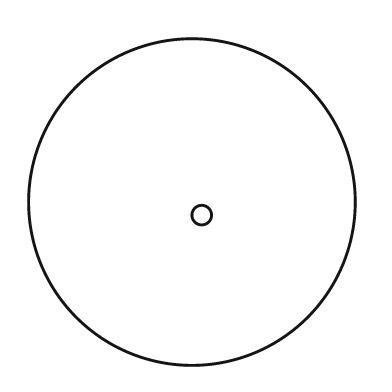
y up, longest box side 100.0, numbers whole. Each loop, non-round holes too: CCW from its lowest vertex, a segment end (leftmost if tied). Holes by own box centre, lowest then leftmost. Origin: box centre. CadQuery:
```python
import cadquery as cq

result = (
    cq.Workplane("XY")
    .moveTo(0.0, 0.0)
    .circle(50.0)
    .moveTo(3.0, -4.0)
    .circle(3.0)
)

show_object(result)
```